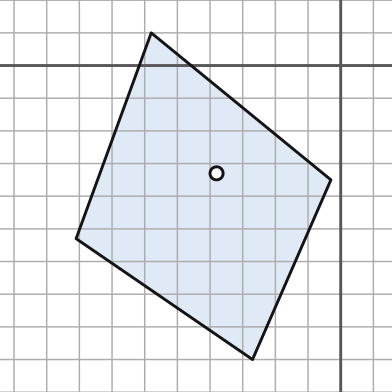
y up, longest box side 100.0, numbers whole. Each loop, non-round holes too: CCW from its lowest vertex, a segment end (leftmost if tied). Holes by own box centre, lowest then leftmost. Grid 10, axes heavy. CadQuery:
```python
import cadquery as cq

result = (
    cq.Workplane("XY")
    .moveTo(-27.0, -90.0)
    .lineTo(-3.0, -35.0)
    .lineTo(-58.0, 10.0)
    .lineTo(-81.0, -53.0)
    .close()
    .moveTo(-38.0, -33.0)
    .circle(2.0)
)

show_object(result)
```